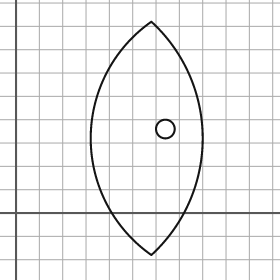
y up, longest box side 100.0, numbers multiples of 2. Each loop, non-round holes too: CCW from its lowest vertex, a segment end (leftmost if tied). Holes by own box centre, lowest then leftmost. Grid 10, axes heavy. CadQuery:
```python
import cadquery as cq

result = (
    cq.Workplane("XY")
    .moveTo(58.0, -18.0)
    .threePointArc((80.0, 32.0), (58.0, 82.0))
    .threePointArc((32.0, 32.0), (58.0, -18.0))
    .close()
    .moveTo(64.0, 36.0)
    .circle(4.0)
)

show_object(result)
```